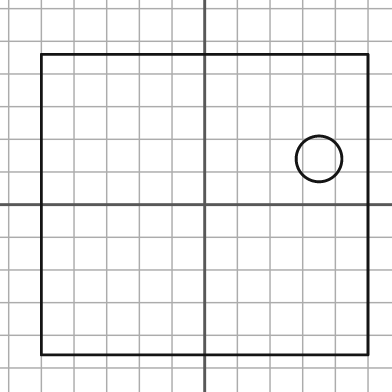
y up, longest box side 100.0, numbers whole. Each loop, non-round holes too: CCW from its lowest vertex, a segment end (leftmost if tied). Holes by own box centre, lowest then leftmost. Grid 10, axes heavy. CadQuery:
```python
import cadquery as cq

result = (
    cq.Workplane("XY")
    .moveTo(-50.0, -46.0)
    .lineTo(50.0, -46.0)
    .lineTo(50.0, 46.0)
    .lineTo(-50.0, 46.0)
    .close()
    .moveTo(35.0, 14.0)
    .circle(7.0)
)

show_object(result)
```